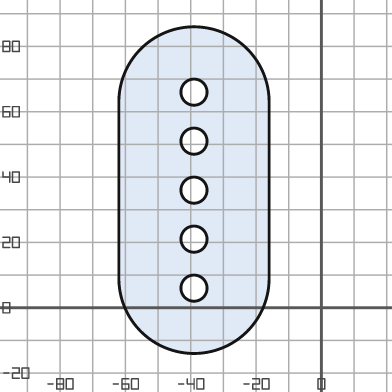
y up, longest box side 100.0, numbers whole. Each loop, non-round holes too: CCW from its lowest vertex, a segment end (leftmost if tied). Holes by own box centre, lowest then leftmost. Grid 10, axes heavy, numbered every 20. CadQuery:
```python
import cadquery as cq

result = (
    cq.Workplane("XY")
    .moveTo(-62.0, 9.0)
    .threePointArc((-39.0, -14.0), (-16.0, 9.0))
    .lineTo(-16.0, 63.0)
    .threePointArc((-39.0, 86.0), (-62.0, 63.0))
    .close()
    .moveTo(-39.0, 6.0)
    .circle(4.0)
    .moveTo(-39.0, 21.0)
    .circle(4.0)
    .moveTo(-39.0, 36.0)
    .circle(4.0)
    .moveTo(-39.0, 51.0)
    .circle(4.0)
    .moveTo(-39.0, 66.0)
    .circle(4.0)
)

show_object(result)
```